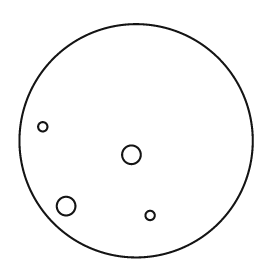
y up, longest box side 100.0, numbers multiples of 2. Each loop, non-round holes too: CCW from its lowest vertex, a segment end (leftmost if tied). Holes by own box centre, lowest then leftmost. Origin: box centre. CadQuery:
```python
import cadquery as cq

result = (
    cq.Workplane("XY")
    .moveTo(0.0, 0.0)
    .circle(50.0)
    .moveTo(6.0, -32.0)
    .circle(2.0)
    .moveTo(-30.0, -28.0)
    .circle(4.0)
    .moveTo(-2.0, -6.0)
    .circle(4.0)
    .moveTo(-40.0, 6.0)
    .circle(2.0)
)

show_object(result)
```